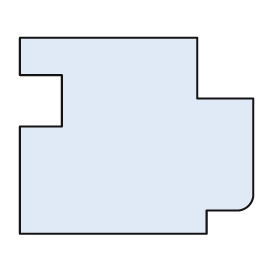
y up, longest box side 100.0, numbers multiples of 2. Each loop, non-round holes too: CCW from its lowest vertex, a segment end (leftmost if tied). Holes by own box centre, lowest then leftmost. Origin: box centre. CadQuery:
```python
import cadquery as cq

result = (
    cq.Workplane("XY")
    .moveTo(-50.0, -42.0)
    .lineTo(30.0, -42.0)
    .lineTo(30.0, -32.0)
    .lineTo(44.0, -32.0)
    .threePointArc((48.0, -30.0), (50.0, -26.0))
    .lineTo(50.0, 16.0)
    .lineTo(26.0, 16.0)
    .lineTo(26.0, 42.0)
    .lineTo(-50.0, 42.0)
    .lineTo(-50.0, 26.0)
    .lineTo(-32.0, 26.0)
    .lineTo(-32.0, 4.0)
    .lineTo(-50.0, 4.0)
    .close()
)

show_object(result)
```